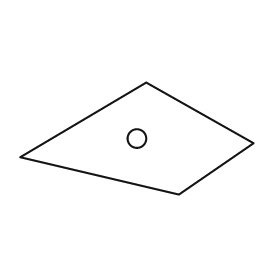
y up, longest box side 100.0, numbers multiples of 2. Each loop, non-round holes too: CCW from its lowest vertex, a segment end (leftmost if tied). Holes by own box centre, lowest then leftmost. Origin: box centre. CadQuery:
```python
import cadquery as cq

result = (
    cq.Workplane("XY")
    .moveTo(18.0, -24.0)
    .lineTo(50.0, -2.0)
    .lineTo(4.0, 24.0)
    .lineTo(-50.0, -8.0)
    .close()
    .moveTo(0.0, 0.0)
    .circle(4.0)
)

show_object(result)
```